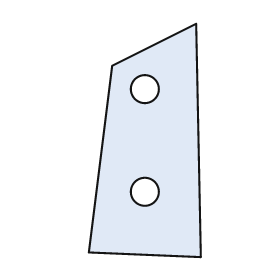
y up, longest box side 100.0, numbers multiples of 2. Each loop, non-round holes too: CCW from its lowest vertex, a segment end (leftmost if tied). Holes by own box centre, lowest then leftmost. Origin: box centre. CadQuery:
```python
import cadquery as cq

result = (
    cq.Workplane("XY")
    .moveTo(24.0, -50.0)
    .lineTo(22.0, 50.0)
    .lineTo(-14.0, 32.0)
    .lineTo(-24.0, -48.0)
    .close()
    .moveTo(0.0, -22.0)
    .circle(6.0)
    .moveTo(0.0, 22.0)
    .circle(6.0)
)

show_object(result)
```